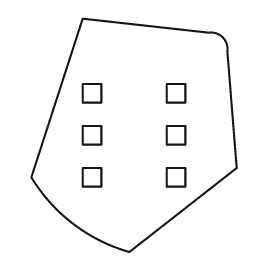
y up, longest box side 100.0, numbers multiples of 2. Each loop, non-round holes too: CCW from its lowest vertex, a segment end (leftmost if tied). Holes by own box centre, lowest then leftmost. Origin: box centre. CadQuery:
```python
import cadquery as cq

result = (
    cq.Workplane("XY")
    .moveTo(-2.0, -50.0)
    .lineTo(44.0, -14.0)
    .lineTo(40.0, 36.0)
    .threePointArc((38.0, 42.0), (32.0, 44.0))
    .lineTo(-22.0, 50.0)
    .lineTo(-44.0, -18.0)
    .threePointArc((-26.0, -38.0), (-2.0, -50.0))
    .close()
    .moveTo(-22.0, -22.0)
    .lineTo(-14.0, -22.0)
    .lineTo(-14.0, -14.0)
    .lineTo(-22.0, -14.0)
    .close()
    .moveTo(14.0, -22.0)
    .lineTo(22.0, -22.0)
    .lineTo(22.0, -14.0)
    .lineTo(14.0, -14.0)
    .close()
    .moveTo(-22.0, -4.0)
    .lineTo(-14.0, -4.0)
    .lineTo(-14.0, 4.0)
    .lineTo(-22.0, 4.0)
    .close()
    .moveTo(14.0, -4.0)
    .lineTo(22.0, -4.0)
    .lineTo(22.0, 4.0)
    .lineTo(14.0, 4.0)
    .close()
    .moveTo(-22.0, 14.0)
    .lineTo(-14.0, 14.0)
    .lineTo(-14.0, 22.0)
    .lineTo(-22.0, 22.0)
    .close()
    .moveTo(14.0, 14.0)
    .lineTo(22.0, 14.0)
    .lineTo(22.0, 22.0)
    .lineTo(14.0, 22.0)
    .close()
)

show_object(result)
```